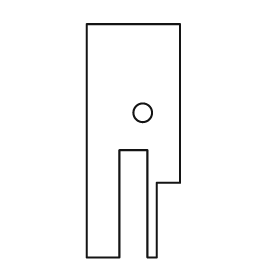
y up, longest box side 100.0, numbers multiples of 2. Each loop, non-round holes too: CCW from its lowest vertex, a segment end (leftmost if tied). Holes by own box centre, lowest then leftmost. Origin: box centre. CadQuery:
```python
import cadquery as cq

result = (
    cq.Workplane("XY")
    .moveTo(-20.0, -50.0)
    .lineTo(-6.0, -50.0)
    .lineTo(-6.0, -4.0)
    .lineTo(6.0, -4.0)
    .lineTo(6.0, -50.0)
    .lineTo(10.0, -50.0)
    .lineTo(10.0, -18.0)
    .lineTo(20.0, -18.0)
    .lineTo(20.0, 50.0)
    .lineTo(-20.0, 50.0)
    .close()
    .moveTo(4.0, 12.0)
    .circle(4.0)
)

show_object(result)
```